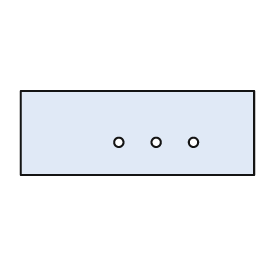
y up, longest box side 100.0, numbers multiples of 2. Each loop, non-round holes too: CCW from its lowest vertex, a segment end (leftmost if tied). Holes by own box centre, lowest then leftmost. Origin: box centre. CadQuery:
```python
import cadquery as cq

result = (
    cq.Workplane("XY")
    .moveTo(-50.0, -18.0)
    .lineTo(50.0, -18.0)
    .lineTo(50.0, 18.0)
    .lineTo(-50.0, 18.0)
    .close()
    .moveTo(-8.0, -4.0)
    .circle(2.0)
    .moveTo(8.0, -4.0)
    .circle(2.0)
    .moveTo(24.0, -4.0)
    .circle(2.0)
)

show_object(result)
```